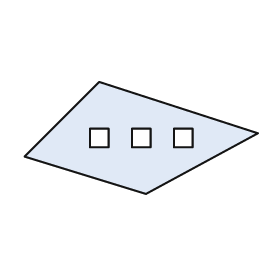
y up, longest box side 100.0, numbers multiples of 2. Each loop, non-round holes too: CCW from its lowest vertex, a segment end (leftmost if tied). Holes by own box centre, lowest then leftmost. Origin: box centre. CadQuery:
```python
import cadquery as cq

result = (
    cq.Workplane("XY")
    .moveTo(2.0, -24.0)
    .lineTo(50.0, 2.0)
    .lineTo(-18.0, 24.0)
    .lineTo(-50.0, -8.0)
    .close()
    .moveTo(-22.0, -4.0)
    .lineTo(-14.0, -4.0)
    .lineTo(-14.0, 4.0)
    .lineTo(-22.0, 4.0)
    .close()
    .moveTo(-4.0, -4.0)
    .lineTo(4.0, -4.0)
    .lineTo(4.0, 4.0)
    .lineTo(-4.0, 4.0)
    .close()
    .moveTo(14.0, -4.0)
    .lineTo(22.0, -4.0)
    .lineTo(22.0, 4.0)
    .lineTo(14.0, 4.0)
    .close()
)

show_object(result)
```